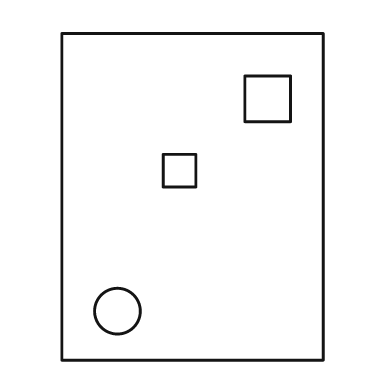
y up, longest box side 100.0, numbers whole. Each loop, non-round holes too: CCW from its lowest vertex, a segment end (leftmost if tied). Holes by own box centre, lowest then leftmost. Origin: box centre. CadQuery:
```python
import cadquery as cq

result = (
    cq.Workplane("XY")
    .moveTo(-40.0, -50.0)
    .lineTo(40.0, -50.0)
    .lineTo(40.0, 50.0)
    .lineTo(-40.0, 50.0)
    .close()
    .moveTo(-23.0, -35.0)
    .circle(7.0)
    .moveTo(-9.0, 3.0)
    .lineTo(1.0, 3.0)
    .lineTo(1.0, 13.0)
    .lineTo(-9.0, 13.0)
    .close()
    .moveTo(16.0, 23.0)
    .lineTo(30.0, 23.0)
    .lineTo(30.0, 37.0)
    .lineTo(16.0, 37.0)
    .close()
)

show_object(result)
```